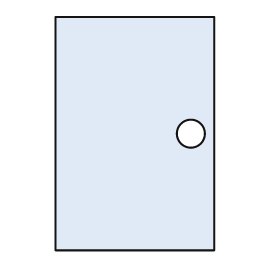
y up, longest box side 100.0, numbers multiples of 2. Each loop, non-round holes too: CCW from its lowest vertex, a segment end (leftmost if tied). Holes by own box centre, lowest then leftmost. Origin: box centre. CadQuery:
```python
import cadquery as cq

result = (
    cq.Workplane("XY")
    .moveTo(-34.0, -50.0)
    .lineTo(34.0, -50.0)
    .lineTo(34.0, 50.0)
    .lineTo(-34.0, 50.0)
    .close()
    .moveTo(24.0, 0.0)
    .circle(6.0)
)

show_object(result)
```